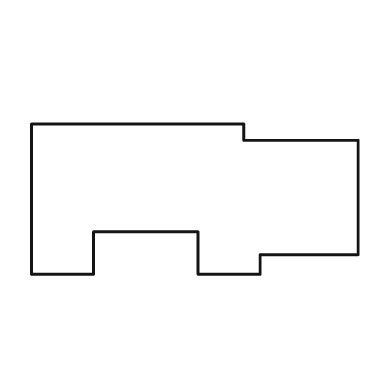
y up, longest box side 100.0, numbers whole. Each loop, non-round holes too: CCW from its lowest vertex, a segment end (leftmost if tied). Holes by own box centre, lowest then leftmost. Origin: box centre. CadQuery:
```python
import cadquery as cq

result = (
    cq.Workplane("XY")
    .moveTo(-50.0, -23.0)
    .lineTo(-31.0, -23.0)
    .lineTo(-31.0, -10.0)
    .lineTo(1.0, -10.0)
    .lineTo(1.0, -23.0)
    .lineTo(20.0, -23.0)
    .lineTo(20.0, -17.0)
    .lineTo(50.0, -17.0)
    .lineTo(50.0, 18.0)
    .lineTo(15.0, 18.0)
    .lineTo(15.0, 23.0)
    .lineTo(-50.0, 23.0)
    .close()
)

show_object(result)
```